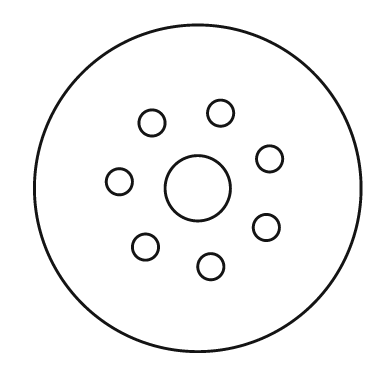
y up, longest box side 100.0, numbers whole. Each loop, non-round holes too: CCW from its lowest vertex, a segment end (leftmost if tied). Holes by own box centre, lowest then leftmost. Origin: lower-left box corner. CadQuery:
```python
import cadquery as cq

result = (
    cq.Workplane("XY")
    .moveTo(50.0, 50.0)
    .circle(50.0)
    .moveTo(54.0, 26.0)
    .circle(4.0)
    .moveTo(34.0, 32.0)
    .circle(4.0)
    .moveTo(71.0, 38.0)
    .circle(4.0)
    .moveTo(50.0, 50.0)
    .circle(10.0)
    .moveTo(26.0, 52.0)
    .circle(4.0)
    .moveTo(72.0, 59.0)
    .circle(4.0)
    .moveTo(36.0, 70.0)
    .circle(4.0)
    .moveTo(57.0, 73.0)
    .circle(4.0)
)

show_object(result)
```